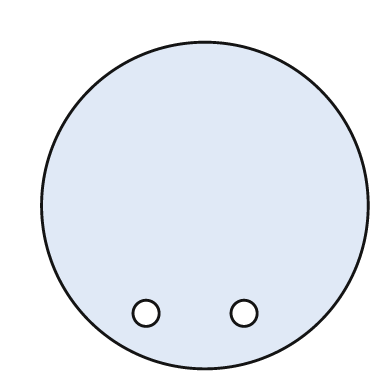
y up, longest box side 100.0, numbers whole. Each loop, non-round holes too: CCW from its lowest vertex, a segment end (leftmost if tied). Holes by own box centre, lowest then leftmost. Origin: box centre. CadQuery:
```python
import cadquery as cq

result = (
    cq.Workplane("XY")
    .moveTo(0.0, 0.0)
    .circle(50.0)
    .moveTo(-18.0, -33.0)
    .circle(4.0)
    .moveTo(12.0, -33.0)
    .circle(4.0)
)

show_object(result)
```